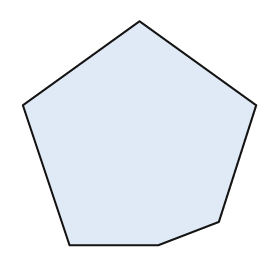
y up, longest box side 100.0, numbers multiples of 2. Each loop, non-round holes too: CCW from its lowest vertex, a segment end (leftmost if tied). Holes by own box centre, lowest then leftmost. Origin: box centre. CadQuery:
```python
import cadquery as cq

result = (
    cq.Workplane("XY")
    .moveTo(-30.0, -48.0)
    .lineTo(8.0, -48.0)
    .lineTo(34.0, -38.0)
    .lineTo(50.0, 12.0)
    .lineTo(0.0, 48.0)
    .lineTo(-50.0, 12.0)
    .close()
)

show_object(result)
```